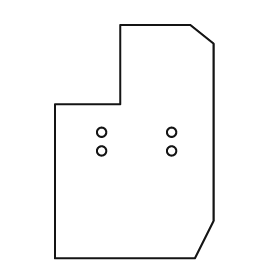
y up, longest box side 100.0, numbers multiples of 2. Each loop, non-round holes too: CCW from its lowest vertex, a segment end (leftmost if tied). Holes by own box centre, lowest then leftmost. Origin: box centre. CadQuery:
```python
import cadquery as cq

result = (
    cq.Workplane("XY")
    .moveTo(-34.0, -50.0)
    .lineTo(26.0, -50.0)
    .lineTo(34.0, -34.0)
    .lineTo(34.0, 42.0)
    .lineTo(24.0, 50.0)
    .lineTo(-6.0, 50.0)
    .lineTo(-6.0, 16.0)
    .lineTo(-34.0, 16.0)
    .close()
    .moveTo(-14.0, -4.0)
    .circle(2.0)
    .moveTo(16.0, -4.0)
    .circle(2.0)
    .moveTo(-14.0, 4.0)
    .circle(2.0)
    .moveTo(16.0, 4.0)
    .circle(2.0)
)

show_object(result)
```